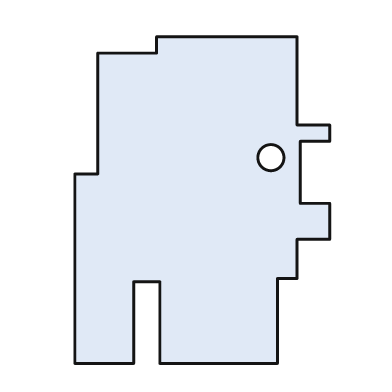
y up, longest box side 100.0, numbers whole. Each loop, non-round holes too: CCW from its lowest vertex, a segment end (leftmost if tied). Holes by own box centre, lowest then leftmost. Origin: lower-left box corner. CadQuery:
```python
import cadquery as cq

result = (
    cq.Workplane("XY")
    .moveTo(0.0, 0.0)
    .lineTo(18.0, 0.0)
    .lineTo(18.0, 25.0)
    .lineTo(26.0, 25.0)
    .lineTo(26.0, 0.0)
    .lineTo(62.0, 0.0)
    .lineTo(62.0, 26.0)
    .lineTo(68.0, 26.0)
    .lineTo(68.0, 38.0)
    .lineTo(78.0, 38.0)
    .lineTo(78.0, 49.0)
    .lineTo(69.0, 49.0)
    .lineTo(69.0, 68.0)
    .lineTo(78.0, 68.0)
    .lineTo(78.0, 73.0)
    .lineTo(68.0, 73.0)
    .lineTo(68.0, 100.0)
    .lineTo(25.0, 100.0)
    .lineTo(25.0, 95.0)
    .lineTo(7.0, 95.0)
    .lineTo(7.0, 58.0)
    .lineTo(0.0, 58.0)
    .close()
    .moveTo(60.0, 63.0)
    .circle(4.0)
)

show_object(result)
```